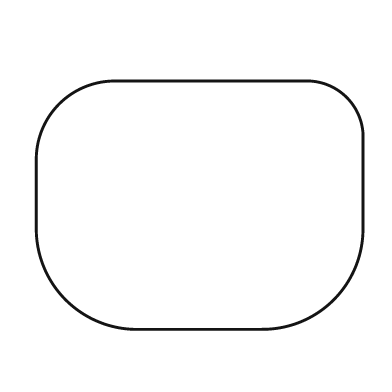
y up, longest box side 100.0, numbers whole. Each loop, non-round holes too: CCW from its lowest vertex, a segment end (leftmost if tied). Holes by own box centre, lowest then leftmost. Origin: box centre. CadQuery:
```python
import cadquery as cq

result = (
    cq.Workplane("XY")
    .moveTo(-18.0, -38.0)
    .lineTo(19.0, -38.0)
    .threePointArc((41.0, -29.0), (50.0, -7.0))
    .lineTo(50.0, 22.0)
    .threePointArc((45.0, 33.0), (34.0, 38.0))
    .lineTo(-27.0, 38.0)
    .threePointArc((-43.0, 31.0), (-50.0, 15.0))
    .lineTo(-50.0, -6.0)
    .threePointArc((-41.0, -29.0), (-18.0, -38.0))
    .close()
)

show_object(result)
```